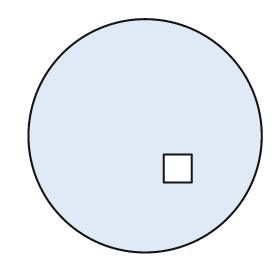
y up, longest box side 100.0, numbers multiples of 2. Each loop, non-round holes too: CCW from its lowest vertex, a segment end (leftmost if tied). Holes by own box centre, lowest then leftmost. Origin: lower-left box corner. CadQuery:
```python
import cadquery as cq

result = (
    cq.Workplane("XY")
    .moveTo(50.0, 50.0)
    .circle(50.0)
    .moveTo(58.0, 30.0)
    .lineTo(70.0, 30.0)
    .lineTo(70.0, 42.0)
    .lineTo(58.0, 42.0)
    .close()
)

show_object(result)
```